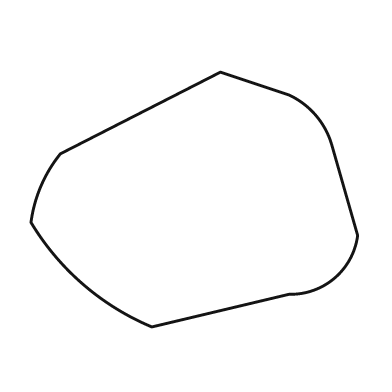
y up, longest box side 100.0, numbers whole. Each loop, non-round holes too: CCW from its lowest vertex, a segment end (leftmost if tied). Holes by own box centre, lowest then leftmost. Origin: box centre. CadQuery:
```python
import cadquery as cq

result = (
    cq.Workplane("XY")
    .moveTo(-13.0, -39.0)
    .lineTo(29.0, -29.0)
    .threePointArc((43.0, -24.0), (50.0, -11.0))
    .lineTo(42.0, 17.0)
    .threePointArc((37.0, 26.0), (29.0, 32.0))
    .lineTo(8.0, 39.0)
    .lineTo(-41.0, 14.0)
    .threePointArc((-47.0, 4.0), (-50.0, -7.0))
    .threePointArc((-34.0, -26.0), (-13.0, -39.0))
    .close()
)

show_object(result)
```